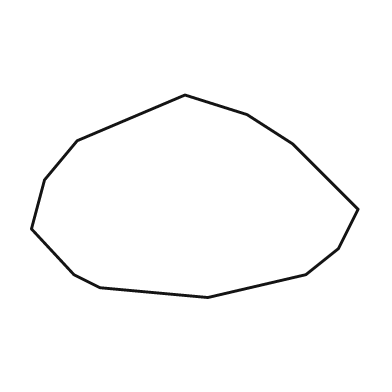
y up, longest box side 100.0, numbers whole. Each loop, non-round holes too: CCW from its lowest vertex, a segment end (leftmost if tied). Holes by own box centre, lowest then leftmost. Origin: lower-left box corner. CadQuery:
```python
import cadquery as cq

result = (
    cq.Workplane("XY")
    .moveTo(54.0, 0.0)
    .lineTo(84.0, 7.0)
    .lineTo(94.0, 15.0)
    .lineTo(100.0, 27.0)
    .lineTo(80.0, 47.0)
    .lineTo(66.0, 56.0)
    .lineTo(47.0, 62.0)
    .lineTo(14.0, 48.0)
    .lineTo(4.0, 36.0)
    .lineTo(0.0, 21.0)
    .lineTo(13.0, 7.0)
    .lineTo(21.0, 3.0)
    .close()
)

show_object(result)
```